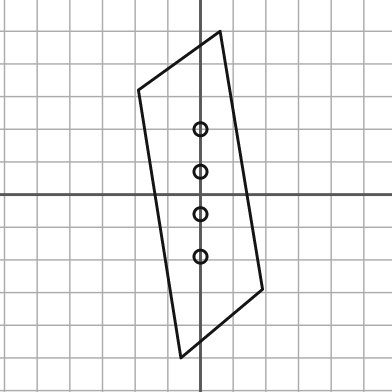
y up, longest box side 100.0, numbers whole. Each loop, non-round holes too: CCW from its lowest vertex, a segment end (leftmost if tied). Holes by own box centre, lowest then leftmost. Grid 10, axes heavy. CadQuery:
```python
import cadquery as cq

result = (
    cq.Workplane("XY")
    .moveTo(-6.0, -50.0)
    .lineTo(19.0, -29.0)
    .lineTo(6.0, 50.0)
    .lineTo(-19.0, 32.0)
    .close()
    .moveTo(0.0, -19.0)
    .circle(2.0)
    .moveTo(0.0, -6.0)
    .circle(2.0)
    .moveTo(0.0, 7.0)
    .circle(2.0)
    .moveTo(0.0, 20.0)
    .circle(2.0)
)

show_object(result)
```